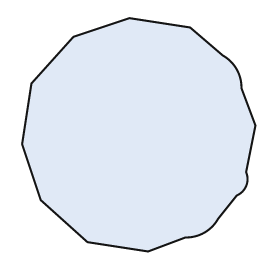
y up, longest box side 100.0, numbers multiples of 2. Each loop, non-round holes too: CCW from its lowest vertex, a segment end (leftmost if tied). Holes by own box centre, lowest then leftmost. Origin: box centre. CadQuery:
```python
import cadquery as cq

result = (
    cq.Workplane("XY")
    .moveTo(4.0, -50.0)
    .lineTo(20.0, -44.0)
    .threePointArc((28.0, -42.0), (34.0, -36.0))
    .lineTo(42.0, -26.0)
    .threePointArc((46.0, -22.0), (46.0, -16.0))
    .lineTo(50.0, 4.0)
    .lineTo(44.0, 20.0)
    .threePointArc((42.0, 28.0), (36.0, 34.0))
    .lineTo(22.0, 46.0)
    .lineTo(-4.0, 50.0)
    .lineTo(-28.0, 42.0)
    .lineTo(-46.0, 22.0)
    .lineTo(-50.0, -4.0)
    .lineTo(-42.0, -28.0)
    .lineTo(-22.0, -46.0)
    .close()
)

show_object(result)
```